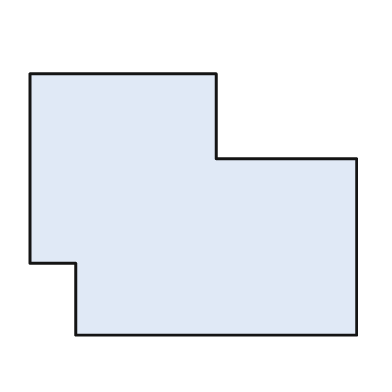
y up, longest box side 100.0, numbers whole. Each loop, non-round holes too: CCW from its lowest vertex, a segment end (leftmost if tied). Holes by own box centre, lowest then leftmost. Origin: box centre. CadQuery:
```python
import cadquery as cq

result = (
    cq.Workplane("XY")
    .moveTo(-36.0, -40.0)
    .lineTo(50.0, -40.0)
    .lineTo(50.0, 14.0)
    .lineTo(7.0, 14.0)
    .lineTo(7.0, 40.0)
    .lineTo(-50.0, 40.0)
    .lineTo(-50.0, -18.0)
    .lineTo(-36.0, -18.0)
    .close()
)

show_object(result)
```